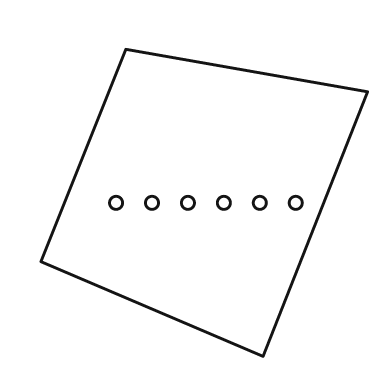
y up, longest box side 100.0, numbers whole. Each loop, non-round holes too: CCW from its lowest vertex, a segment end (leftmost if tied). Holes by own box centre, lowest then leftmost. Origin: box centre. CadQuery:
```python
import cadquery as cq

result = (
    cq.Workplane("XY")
    .moveTo(18.0, -47.0)
    .lineTo(50.0, 34.0)
    .lineTo(-24.0, 47.0)
    .lineTo(-50.0, -18.0)
    .close()
    .moveTo(-27.0, 0.0)
    .circle(2.0)
    .moveTo(-16.0, 0.0)
    .circle(2.0)
    .moveTo(-5.0, 0.0)
    .circle(2.0)
    .moveTo(6.0, 0.0)
    .circle(2.0)
    .moveTo(17.0, 0.0)
    .circle(2.0)
    .moveTo(28.0, 0.0)
    .circle(2.0)
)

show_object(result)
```